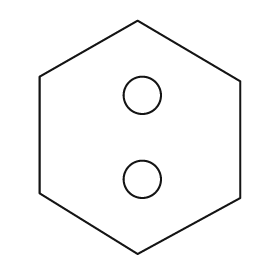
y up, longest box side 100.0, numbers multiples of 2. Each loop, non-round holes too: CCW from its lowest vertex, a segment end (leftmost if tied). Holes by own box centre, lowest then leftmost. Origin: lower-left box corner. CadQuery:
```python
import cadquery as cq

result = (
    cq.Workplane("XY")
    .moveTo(42.0, 0.0)
    .lineTo(86.0, 24.0)
    .lineTo(86.0, 74.0)
    .lineTo(42.0, 100.0)
    .lineTo(0.0, 76.0)
    .lineTo(0.0, 26.0)
    .close()
    .moveTo(44.0, 32.0)
    .circle(8.0)
    .moveTo(44.0, 68.0)
    .circle(8.0)
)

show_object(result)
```